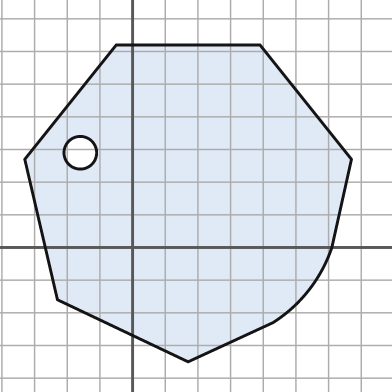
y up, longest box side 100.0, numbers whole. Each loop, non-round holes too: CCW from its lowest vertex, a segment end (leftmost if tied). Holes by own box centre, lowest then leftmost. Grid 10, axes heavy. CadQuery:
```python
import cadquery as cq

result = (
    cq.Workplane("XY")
    .moveTo(17.0, -35.0)
    .lineTo(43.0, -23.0)
    .threePointArc((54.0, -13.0), (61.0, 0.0))
    .lineTo(67.0, 27.0)
    .lineTo(39.0, 62.0)
    .lineTo(-5.0, 62.0)
    .lineTo(-33.0, 27.0)
    .lineTo(-23.0, -16.0)
    .close()
    .moveTo(-16.0, 29.0)
    .circle(5.0)
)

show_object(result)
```